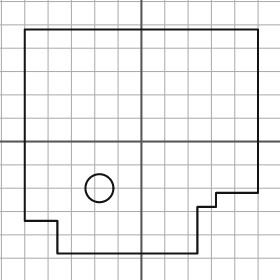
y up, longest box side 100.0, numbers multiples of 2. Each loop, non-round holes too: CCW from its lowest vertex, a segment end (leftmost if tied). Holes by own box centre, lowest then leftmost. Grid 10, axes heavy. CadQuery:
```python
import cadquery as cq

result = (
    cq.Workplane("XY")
    .moveTo(-36.0, -48.0)
    .lineTo(24.0, -48.0)
    .lineTo(24.0, -28.0)
    .lineTo(32.0, -28.0)
    .lineTo(32.0, -22.0)
    .lineTo(50.0, -22.0)
    .lineTo(50.0, 48.0)
    .lineTo(-50.0, 48.0)
    .lineTo(-50.0, -34.0)
    .lineTo(-36.0, -34.0)
    .close()
    .moveTo(-18.0, -20.0)
    .circle(6.0)
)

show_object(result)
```